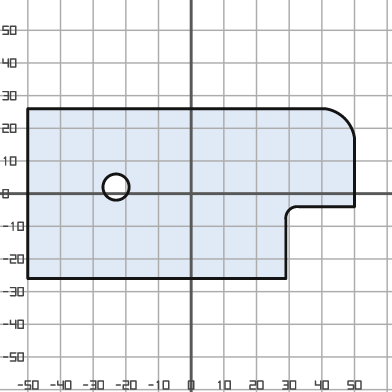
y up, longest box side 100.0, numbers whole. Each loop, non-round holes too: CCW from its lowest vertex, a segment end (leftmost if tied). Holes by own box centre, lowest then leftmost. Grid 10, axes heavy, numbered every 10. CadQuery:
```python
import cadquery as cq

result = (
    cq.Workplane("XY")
    .moveTo(-50.0, -26.0)
    .lineTo(29.0, -26.0)
    .lineTo(29.0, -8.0)
    .threePointArc((30.0, -5.0), (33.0, -4.0))
    .lineTo(50.0, -4.0)
    .lineTo(50.0, 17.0)
    .threePointArc((47.0, 23.0), (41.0, 26.0))
    .lineTo(-50.0, 26.0)
    .close()
    .moveTo(-23.0, 2.0)
    .circle(4.0)
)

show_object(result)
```